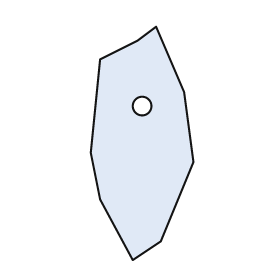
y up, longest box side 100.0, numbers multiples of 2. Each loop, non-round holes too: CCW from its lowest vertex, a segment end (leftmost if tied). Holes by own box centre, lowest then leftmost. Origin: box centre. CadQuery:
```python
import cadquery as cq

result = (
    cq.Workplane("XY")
    .moveTo(-4.0, -50.0)
    .lineTo(8.0, -42.0)
    .lineTo(22.0, -8.0)
    .lineTo(18.0, 22.0)
    .lineTo(6.0, 50.0)
    .lineTo(-2.0, 44.0)
    .lineTo(-18.0, 36.0)
    .lineTo(-22.0, -4.0)
    .lineTo(-18.0, -24.0)
    .close()
    .moveTo(0.0, 16.0)
    .circle(4.0)
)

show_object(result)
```